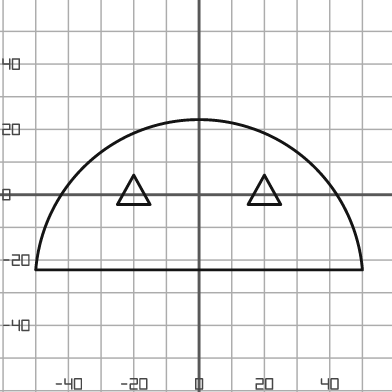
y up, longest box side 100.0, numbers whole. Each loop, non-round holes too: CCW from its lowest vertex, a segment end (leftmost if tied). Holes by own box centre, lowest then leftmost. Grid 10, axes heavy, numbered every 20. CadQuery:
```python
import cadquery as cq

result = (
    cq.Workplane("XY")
    .moveTo(-50.0, -23.0)
    .lineTo(50.0, -23.0)
    .threePointArc((0.0, 23.0), (-50.0, -23.0))
    .close()
    .moveTo(-25.0, -3.0)
    .lineTo(-15.0, -3.0)
    .lineTo(-20.0, 6.0)
    .close()
    .moveTo(15.0, -3.0)
    .lineTo(25.0, -3.0)
    .lineTo(20.0, 6.0)
    .close()
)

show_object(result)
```